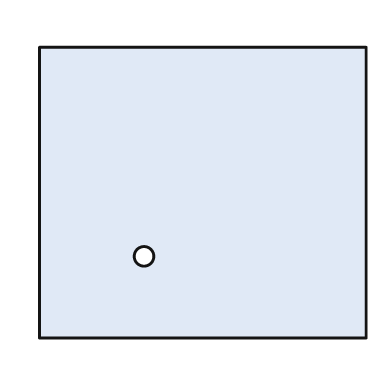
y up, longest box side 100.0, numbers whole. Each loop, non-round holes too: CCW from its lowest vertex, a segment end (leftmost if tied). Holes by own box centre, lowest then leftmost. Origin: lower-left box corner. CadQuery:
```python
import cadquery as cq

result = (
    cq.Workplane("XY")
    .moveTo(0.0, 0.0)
    .lineTo(100.0, 0.0)
    .lineTo(100.0, 89.0)
    .lineTo(0.0, 89.0)
    .close()
    .moveTo(32.0, 25.0)
    .circle(3.0)
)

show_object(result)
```